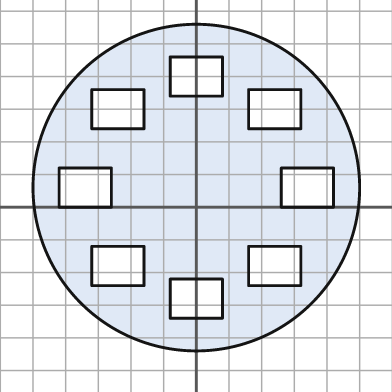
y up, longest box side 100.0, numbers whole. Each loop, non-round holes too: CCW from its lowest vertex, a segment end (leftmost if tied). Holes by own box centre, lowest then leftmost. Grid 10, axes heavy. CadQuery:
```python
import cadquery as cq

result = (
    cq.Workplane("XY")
    .moveTo(0.0, 6.0)
    .circle(50.0)
    .moveTo(-8.0, -34.0)
    .lineTo(8.0, -34.0)
    .lineTo(8.0, -22.0)
    .lineTo(-8.0, -22.0)
    .close()
    .moveTo(-32.0, -24.0)
    .lineTo(-16.0, -24.0)
    .lineTo(-16.0, -12.0)
    .lineTo(-32.0, -12.0)
    .close()
    .moveTo(16.0, -24.0)
    .lineTo(32.0, -24.0)
    .lineTo(32.0, -12.0)
    .lineTo(16.0, -12.0)
    .close()
    .moveTo(-42.0, 0.0)
    .lineTo(-26.0, 0.0)
    .lineTo(-26.0, 12.0)
    .lineTo(-42.0, 12.0)
    .close()
    .moveTo(26.0, 0.0)
    .lineTo(42.0, 0.0)
    .lineTo(42.0, 12.0)
    .lineTo(26.0, 12.0)
    .close()
    .moveTo(-32.0, 24.0)
    .lineTo(-16.0, 24.0)
    .lineTo(-16.0, 36.0)
    .lineTo(-32.0, 36.0)
    .close()
    .moveTo(16.0, 24.0)
    .lineTo(32.0, 24.0)
    .lineTo(32.0, 36.0)
    .lineTo(16.0, 36.0)
    .close()
    .moveTo(-8.0, 34.0)
    .lineTo(8.0, 34.0)
    .lineTo(8.0, 46.0)
    .lineTo(-8.0, 46.0)
    .close()
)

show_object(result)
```